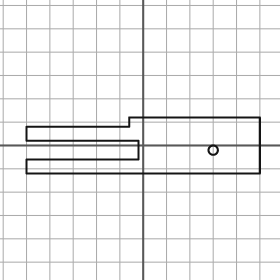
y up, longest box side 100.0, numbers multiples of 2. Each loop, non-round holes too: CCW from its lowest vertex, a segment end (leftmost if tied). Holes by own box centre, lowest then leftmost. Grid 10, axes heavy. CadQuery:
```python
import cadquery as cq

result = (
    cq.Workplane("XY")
    .moveTo(-50.0, -12.0)
    .lineTo(50.0, -12.0)
    .lineTo(50.0, 12.0)
    .lineTo(-6.0, 12.0)
    .lineTo(-6.0, 8.0)
    .lineTo(-50.0, 8.0)
    .lineTo(-50.0, 2.0)
    .lineTo(-2.0, 2.0)
    .lineTo(-2.0, -6.0)
    .lineTo(-50.0, -6.0)
    .close()
    .moveTo(30.0, -2.0)
    .circle(2.0)
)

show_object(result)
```